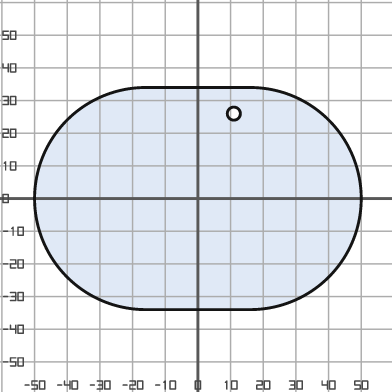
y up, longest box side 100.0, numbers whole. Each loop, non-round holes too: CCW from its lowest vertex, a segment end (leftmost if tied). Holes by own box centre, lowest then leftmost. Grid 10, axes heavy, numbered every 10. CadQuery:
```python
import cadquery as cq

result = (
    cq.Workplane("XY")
    .moveTo(-16.0, -34.0)
    .lineTo(16.0, -34.0)
    .threePointArc((50.0, 0.0), (16.0, 34.0))
    .lineTo(-16.0, 34.0)
    .threePointArc((-50.0, 0.0), (-16.0, -34.0))
    .close()
    .moveTo(11.0, 26.0)
    .circle(2.0)
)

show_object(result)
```